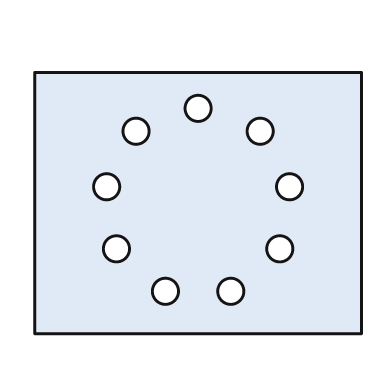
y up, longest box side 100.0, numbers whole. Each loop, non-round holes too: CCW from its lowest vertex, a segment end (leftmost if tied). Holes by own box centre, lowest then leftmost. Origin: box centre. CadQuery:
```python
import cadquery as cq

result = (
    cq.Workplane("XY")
    .moveTo(-50.0, -40.0)
    .lineTo(50.0, -40.0)
    .lineTo(50.0, 40.0)
    .lineTo(-50.0, 40.0)
    .close()
    .moveTo(-10.0, -27.0)
    .circle(4.0)
    .moveTo(10.0, -27.0)
    .circle(4.0)
    .moveTo(-25.0, -14.0)
    .circle(4.0)
    .moveTo(25.0, -14.0)
    .circle(4.0)
    .moveTo(-28.0, 5.0)
    .circle(4.0)
    .moveTo(28.0, 5.0)
    .circle(4.0)
    .moveTo(-19.0, 22.0)
    .circle(4.0)
    .moveTo(19.0, 22.0)
    .circle(4.0)
    .moveTo(0.0, 29.0)
    .circle(4.0)
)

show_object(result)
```